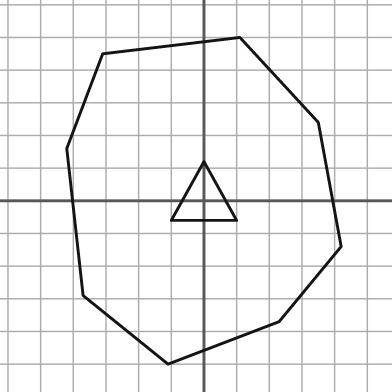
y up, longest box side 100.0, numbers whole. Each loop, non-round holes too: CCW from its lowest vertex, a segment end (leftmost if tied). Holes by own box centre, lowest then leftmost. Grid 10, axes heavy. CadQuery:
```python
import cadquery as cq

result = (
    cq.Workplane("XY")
    .moveTo(-11.0, -50.0)
    .lineTo(23.0, -37.0)
    .lineTo(42.0, -14.0)
    .lineTo(35.0, 24.0)
    .lineTo(11.0, 50.0)
    .lineTo(-31.0, 45.0)
    .lineTo(-42.0, 16.0)
    .lineTo(-37.0, -29.0)
    .close()
    .moveTo(-10.0, -6.0)
    .lineTo(10.0, -6.0)
    .lineTo(0.0, 12.0)
    .close()
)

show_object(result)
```